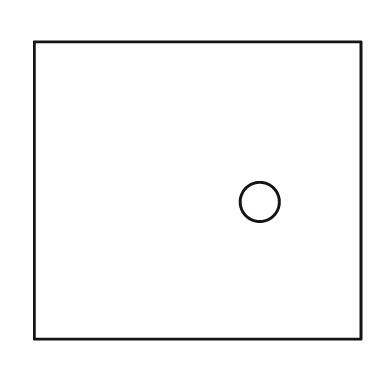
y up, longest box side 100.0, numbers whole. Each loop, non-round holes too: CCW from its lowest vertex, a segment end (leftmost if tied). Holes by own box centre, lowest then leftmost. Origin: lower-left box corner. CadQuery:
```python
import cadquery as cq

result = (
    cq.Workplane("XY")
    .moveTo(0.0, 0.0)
    .lineTo(100.0, 0.0)
    .lineTo(100.0, 91.0)
    .lineTo(0.0, 91.0)
    .close()
    .moveTo(69.0, 42.0)
    .circle(6.0)
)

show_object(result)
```